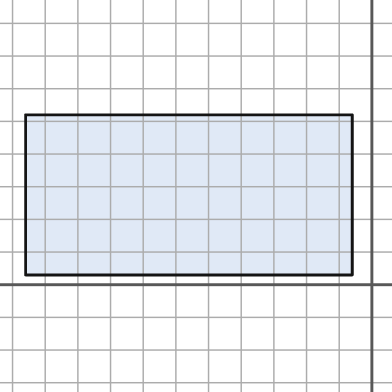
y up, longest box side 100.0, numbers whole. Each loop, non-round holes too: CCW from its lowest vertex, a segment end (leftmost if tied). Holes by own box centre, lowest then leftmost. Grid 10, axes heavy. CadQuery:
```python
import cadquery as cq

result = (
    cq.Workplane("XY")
    .moveTo(-106.0, 3.0)
    .lineTo(-6.0, 3.0)
    .lineTo(-6.0, 52.0)
    .lineTo(-106.0, 52.0)
    .close()
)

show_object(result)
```